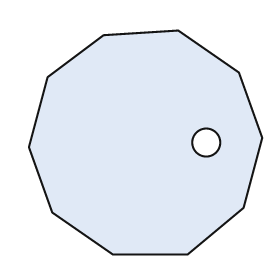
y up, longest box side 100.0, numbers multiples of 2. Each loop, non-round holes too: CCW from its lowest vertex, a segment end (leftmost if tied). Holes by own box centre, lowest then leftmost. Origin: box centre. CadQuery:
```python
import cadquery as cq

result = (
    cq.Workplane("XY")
    .moveTo(-14.0, -48.0)
    .lineTo(18.0, -48.0)
    .lineTo(42.0, -28.0)
    .lineTo(50.0, 2.0)
    .lineTo(40.0, 30.0)
    .lineTo(14.0, 48.0)
    .lineTo(-18.0, 46.0)
    .lineTo(-42.0, 28.0)
    .lineTo(-50.0, -2.0)
    .lineTo(-40.0, -30.0)
    .close()
    .moveTo(26.0, 0.0)
    .circle(6.0)
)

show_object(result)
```